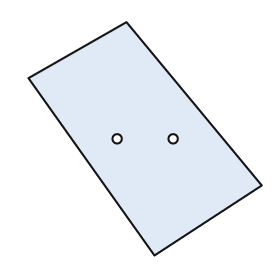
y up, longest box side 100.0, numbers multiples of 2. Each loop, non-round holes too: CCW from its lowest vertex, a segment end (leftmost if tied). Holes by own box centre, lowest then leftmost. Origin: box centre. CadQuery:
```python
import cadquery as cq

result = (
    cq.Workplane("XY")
    .moveTo(4.0, -50.0)
    .lineTo(50.0, -20.0)
    .lineTo(-8.0, 50.0)
    .lineTo(-50.0, 26.0)
    .close()
    .moveTo(-12.0, 0.0)
    .circle(2.0)
    .moveTo(12.0, 0.0)
    .circle(2.0)
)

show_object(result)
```